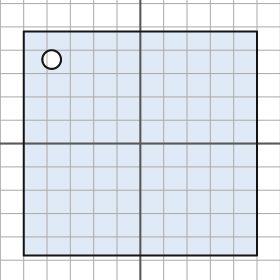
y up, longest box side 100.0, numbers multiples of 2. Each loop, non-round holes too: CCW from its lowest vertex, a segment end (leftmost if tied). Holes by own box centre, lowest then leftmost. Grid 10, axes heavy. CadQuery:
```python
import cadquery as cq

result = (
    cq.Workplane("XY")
    .moveTo(-50.0, -48.0)
    .lineTo(50.0, -48.0)
    .lineTo(50.0, 48.0)
    .lineTo(-50.0, 48.0)
    .close()
    .moveTo(-38.0, 36.0)
    .circle(4.0)
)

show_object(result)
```